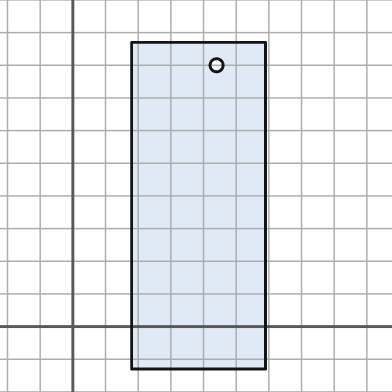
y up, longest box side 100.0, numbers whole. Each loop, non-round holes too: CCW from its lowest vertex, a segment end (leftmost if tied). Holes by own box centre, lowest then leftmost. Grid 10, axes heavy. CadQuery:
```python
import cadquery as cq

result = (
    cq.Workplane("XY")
    .moveTo(18.0, -13.0)
    .lineTo(59.0, -13.0)
    .lineTo(59.0, 87.0)
    .lineTo(18.0, 87.0)
    .close()
    .moveTo(44.0, 80.0)
    .circle(2.0)
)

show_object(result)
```